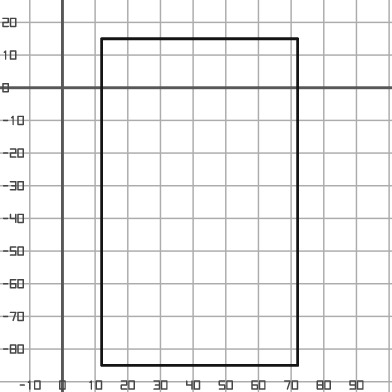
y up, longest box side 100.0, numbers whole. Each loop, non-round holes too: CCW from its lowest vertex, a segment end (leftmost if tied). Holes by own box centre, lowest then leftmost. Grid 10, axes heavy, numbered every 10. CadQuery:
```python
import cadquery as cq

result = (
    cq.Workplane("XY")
    .moveTo(12.0, -85.0)
    .lineTo(72.0, -85.0)
    .lineTo(72.0, 15.0)
    .lineTo(12.0, 15.0)
    .close()
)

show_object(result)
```